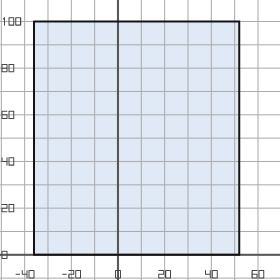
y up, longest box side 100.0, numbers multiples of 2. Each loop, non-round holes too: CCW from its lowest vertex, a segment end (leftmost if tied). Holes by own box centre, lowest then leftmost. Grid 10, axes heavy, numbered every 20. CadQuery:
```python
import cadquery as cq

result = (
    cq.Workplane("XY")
    .moveTo(-36.0, 0.0)
    .lineTo(52.0, 0.0)
    .lineTo(52.0, 100.0)
    .lineTo(-36.0, 100.0)
    .close()
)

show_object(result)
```